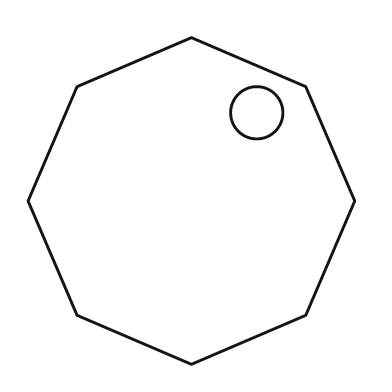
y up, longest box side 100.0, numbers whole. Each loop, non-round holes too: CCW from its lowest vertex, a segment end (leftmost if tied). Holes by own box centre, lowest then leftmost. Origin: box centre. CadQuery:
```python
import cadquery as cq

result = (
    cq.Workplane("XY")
    .moveTo(0.0, -50.0)
    .lineTo(35.0, -35.0)
    .lineTo(50.0, 0.0)
    .lineTo(35.0, 35.0)
    .lineTo(0.0, 50.0)
    .lineTo(-35.0, 35.0)
    .lineTo(-50.0, 0.0)
    .lineTo(-35.0, -35.0)
    .close()
    .moveTo(20.0, 27.0)
    .circle(8.0)
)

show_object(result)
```